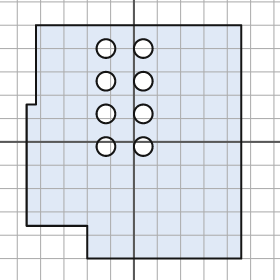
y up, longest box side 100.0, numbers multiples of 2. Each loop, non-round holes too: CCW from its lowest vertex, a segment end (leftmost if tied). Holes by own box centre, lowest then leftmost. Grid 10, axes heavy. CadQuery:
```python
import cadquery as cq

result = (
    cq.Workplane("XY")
    .moveTo(-20.0, -50.0)
    .lineTo(46.0, -50.0)
    .lineTo(46.0, 50.0)
    .lineTo(-42.0, 50.0)
    .lineTo(-42.0, 16.0)
    .lineTo(-46.0, 16.0)
    .lineTo(-46.0, -36.0)
    .lineTo(-20.0, -36.0)
    .close()
    .moveTo(-12.0, -2.0)
    .circle(4.0)
    .moveTo(4.0, -2.0)
    .circle(4.0)
    .moveTo(-12.0, 12.0)
    .circle(4.0)
    .moveTo(4.0, 12.0)
    .circle(4.0)
    .moveTo(-12.0, 26.0)
    .circle(4.0)
    .moveTo(4.0, 26.0)
    .circle(4.0)
    .moveTo(-12.0, 40.0)
    .circle(4.0)
    .moveTo(4.0, 40.0)
    .circle(4.0)
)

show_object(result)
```